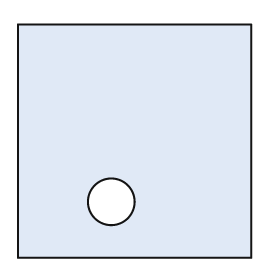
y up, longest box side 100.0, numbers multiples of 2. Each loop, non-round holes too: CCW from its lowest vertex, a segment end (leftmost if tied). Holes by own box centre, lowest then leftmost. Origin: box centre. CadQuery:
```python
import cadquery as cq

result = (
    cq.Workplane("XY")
    .moveTo(-50.0, -50.0)
    .lineTo(50.0, -50.0)
    .lineTo(50.0, 50.0)
    .lineTo(-50.0, 50.0)
    .close()
    .moveTo(-10.0, -26.0)
    .circle(10.0)
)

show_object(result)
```